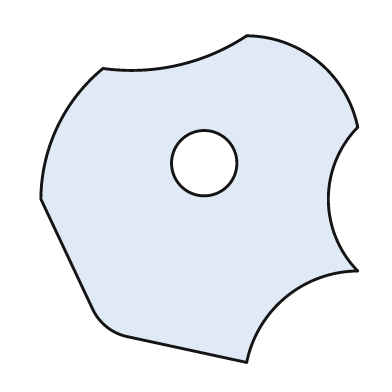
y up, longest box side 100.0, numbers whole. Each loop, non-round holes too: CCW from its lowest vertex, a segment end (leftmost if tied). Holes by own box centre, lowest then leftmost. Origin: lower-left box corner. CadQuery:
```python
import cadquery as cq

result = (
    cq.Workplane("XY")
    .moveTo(63.0, 0.0)
    .threePointArc((75.0, 20.0), (97.0, 28.0))
    .threePointArc((88.0, 50.0), (97.0, 72.0))
    .threePointArc((85.0, 92.0), (63.0, 100.0))
    .threePointArc((42.0, 91.0), (19.0, 90.0))
    .threePointArc((5.0, 72.0), (0.0, 50.0))
    .lineTo(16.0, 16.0)
    .threePointArc((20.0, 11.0), (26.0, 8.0))
    .close()
    .moveTo(50.0, 61.0)
    .circle(10.0)
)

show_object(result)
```